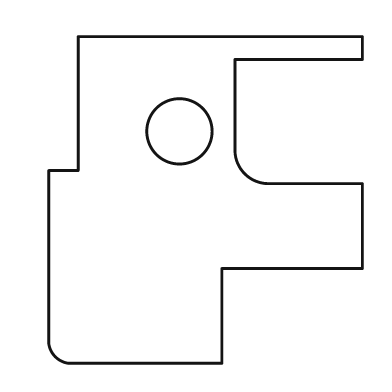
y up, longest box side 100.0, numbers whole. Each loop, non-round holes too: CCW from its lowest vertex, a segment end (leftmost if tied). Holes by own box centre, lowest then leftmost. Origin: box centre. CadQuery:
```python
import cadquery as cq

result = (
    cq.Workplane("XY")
    .moveTo(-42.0, -50.0)
    .lineTo(5.0, -50.0)
    .lineTo(5.0, -21.0)
    .lineTo(48.0, -21.0)
    .lineTo(48.0, 5.0)
    .lineTo(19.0, 5.0)
    .threePointArc((12.0, 8.0), (9.0, 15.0))
    .lineTo(9.0, 43.0)
    .lineTo(48.0, 43.0)
    .lineTo(48.0, 50.0)
    .lineTo(-39.0, 50.0)
    .lineTo(-39.0, 9.0)
    .lineTo(-48.0, 9.0)
    .lineTo(-48.0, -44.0)
    .threePointArc((-46.0, -48.0), (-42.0, -50.0))
    .close()
    .moveTo(-8.0, 21.0)
    .circle(10.0)
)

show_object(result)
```